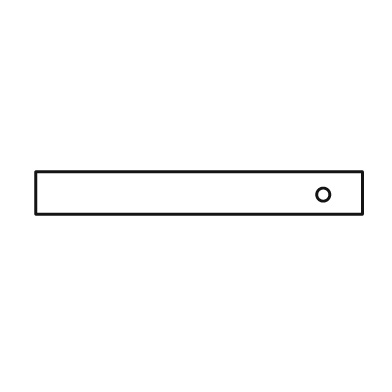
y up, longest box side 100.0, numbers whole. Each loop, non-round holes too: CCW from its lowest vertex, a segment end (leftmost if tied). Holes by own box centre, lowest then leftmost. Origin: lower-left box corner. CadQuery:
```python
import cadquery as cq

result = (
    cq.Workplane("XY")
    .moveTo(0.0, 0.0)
    .lineTo(100.0, 0.0)
    .lineTo(100.0, 13.0)
    .lineTo(0.0, 13.0)
    .close()
    .moveTo(88.0, 6.0)
    .circle(2.0)
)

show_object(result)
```